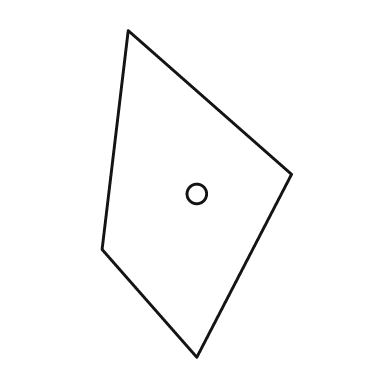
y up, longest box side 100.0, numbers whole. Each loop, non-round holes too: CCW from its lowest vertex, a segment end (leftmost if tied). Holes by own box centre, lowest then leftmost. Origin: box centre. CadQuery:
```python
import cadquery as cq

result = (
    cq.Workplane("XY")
    .moveTo(0.0, -50.0)
    .lineTo(29.0, 6.0)
    .lineTo(-21.0, 50.0)
    .lineTo(-29.0, -17.0)
    .close()
    .moveTo(0.0, 0.0)
    .circle(3.0)
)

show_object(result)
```